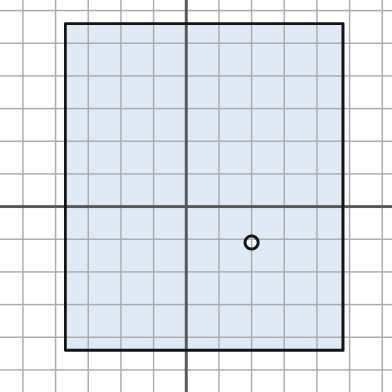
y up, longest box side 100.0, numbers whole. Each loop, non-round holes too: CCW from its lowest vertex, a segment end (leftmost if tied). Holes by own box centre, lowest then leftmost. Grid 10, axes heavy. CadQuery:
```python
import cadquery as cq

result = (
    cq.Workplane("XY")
    .moveTo(-37.0, -44.0)
    .lineTo(48.0, -44.0)
    .lineTo(48.0, 56.0)
    .lineTo(-37.0, 56.0)
    .close()
    .moveTo(20.0, -11.0)
    .circle(2.0)
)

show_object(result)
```